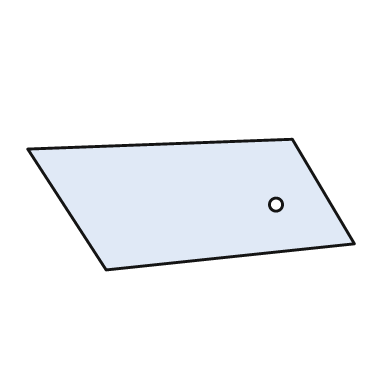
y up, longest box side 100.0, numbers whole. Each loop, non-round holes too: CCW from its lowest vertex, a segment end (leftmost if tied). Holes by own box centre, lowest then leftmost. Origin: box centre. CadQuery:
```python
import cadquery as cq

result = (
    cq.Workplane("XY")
    .moveTo(-26.0, -20.0)
    .lineTo(50.0, -12.0)
    .lineTo(31.0, 20.0)
    .lineTo(-50.0, 17.0)
    .close()
    .moveTo(26.0, 0.0)
    .circle(2.0)
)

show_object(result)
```